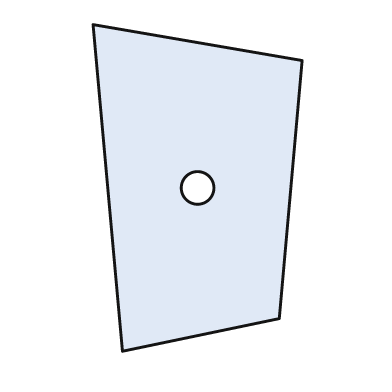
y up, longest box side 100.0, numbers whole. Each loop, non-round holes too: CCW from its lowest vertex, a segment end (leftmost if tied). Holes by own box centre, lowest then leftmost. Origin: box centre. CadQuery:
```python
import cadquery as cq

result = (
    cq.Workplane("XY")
    .moveTo(-23.0, -50.0)
    .lineTo(25.0, -40.0)
    .lineTo(32.0, 39.0)
    .lineTo(-32.0, 50.0)
    .close()
    .moveTo(0.0, 0.0)
    .circle(5.0)
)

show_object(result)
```